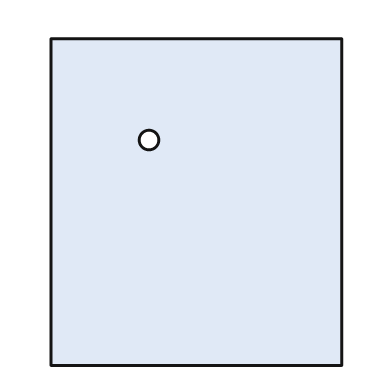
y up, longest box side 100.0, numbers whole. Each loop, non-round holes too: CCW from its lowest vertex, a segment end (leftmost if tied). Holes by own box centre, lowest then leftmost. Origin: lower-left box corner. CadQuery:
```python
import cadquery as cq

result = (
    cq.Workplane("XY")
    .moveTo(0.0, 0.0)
    .lineTo(89.0, 0.0)
    .lineTo(89.0, 100.0)
    .lineTo(0.0, 100.0)
    .close()
    .moveTo(30.0, 69.0)
    .circle(3.0)
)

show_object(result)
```